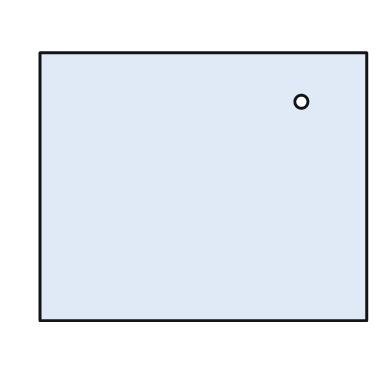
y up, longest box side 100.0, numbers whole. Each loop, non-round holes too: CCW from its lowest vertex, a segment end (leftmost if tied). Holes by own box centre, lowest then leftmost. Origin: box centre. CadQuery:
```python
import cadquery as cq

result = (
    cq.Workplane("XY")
    .moveTo(-50.0, -41.0)
    .lineTo(50.0, -41.0)
    .lineTo(50.0, 41.0)
    .lineTo(-50.0, 41.0)
    .close()
    .moveTo(30.0, 26.0)
    .circle(2.0)
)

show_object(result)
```